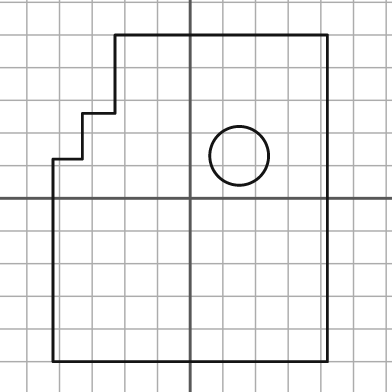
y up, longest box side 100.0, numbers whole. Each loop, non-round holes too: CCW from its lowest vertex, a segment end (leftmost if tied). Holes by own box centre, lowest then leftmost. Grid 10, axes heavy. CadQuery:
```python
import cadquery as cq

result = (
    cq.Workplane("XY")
    .moveTo(-42.0, -50.0)
    .lineTo(42.0, -50.0)
    .lineTo(42.0, 50.0)
    .lineTo(-23.0, 50.0)
    .lineTo(-23.0, 26.0)
    .lineTo(-33.0, 26.0)
    .lineTo(-33.0, 12.0)
    .lineTo(-42.0, 12.0)
    .close()
    .moveTo(15.0, 13.0)
    .circle(9.0)
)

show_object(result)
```